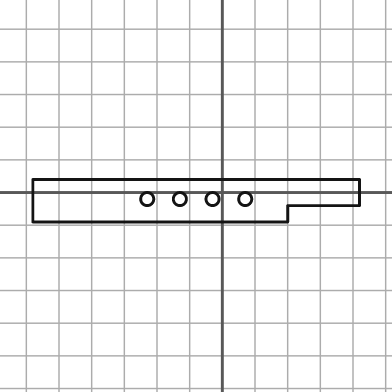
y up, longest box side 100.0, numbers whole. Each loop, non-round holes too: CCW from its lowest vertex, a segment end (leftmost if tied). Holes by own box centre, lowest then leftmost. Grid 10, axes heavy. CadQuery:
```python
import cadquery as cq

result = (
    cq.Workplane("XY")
    .moveTo(-58.0, -9.0)
    .lineTo(20.0, -9.0)
    .lineTo(20.0, -4.0)
    .lineTo(42.0, -4.0)
    .lineTo(42.0, 4.0)
    .lineTo(-58.0, 4.0)
    .close()
    .moveTo(-23.0, -2.0)
    .circle(2.0)
    .moveTo(-13.0, -2.0)
    .circle(2.0)
    .moveTo(-3.0, -2.0)
    .circle(2.0)
    .moveTo(7.0, -2.0)
    .circle(2.0)
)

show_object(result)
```